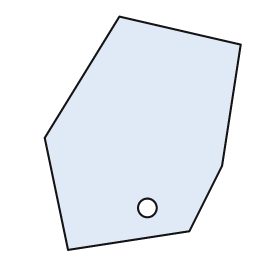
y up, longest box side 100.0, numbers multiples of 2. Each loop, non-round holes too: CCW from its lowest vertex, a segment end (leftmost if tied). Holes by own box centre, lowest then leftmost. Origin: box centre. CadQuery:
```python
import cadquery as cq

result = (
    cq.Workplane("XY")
    .moveTo(-32.0, -50.0)
    .lineTo(20.0, -42.0)
    .lineTo(34.0, -14.0)
    .lineTo(42.0, 38.0)
    .lineTo(-10.0, 50.0)
    .lineTo(-42.0, -2.0)
    .close()
    .moveTo(2.0, -32.0)
    .circle(4.0)
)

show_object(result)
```